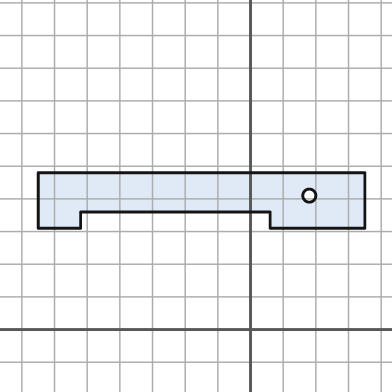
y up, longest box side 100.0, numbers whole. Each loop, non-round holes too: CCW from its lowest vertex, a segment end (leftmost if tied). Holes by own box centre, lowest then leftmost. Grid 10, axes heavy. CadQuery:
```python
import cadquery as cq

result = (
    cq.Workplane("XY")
    .moveTo(-65.0, 31.0)
    .lineTo(-52.0, 31.0)
    .lineTo(-52.0, 36.0)
    .lineTo(6.0, 36.0)
    .lineTo(6.0, 31.0)
    .lineTo(35.0, 31.0)
    .lineTo(35.0, 48.0)
    .lineTo(-65.0, 48.0)
    .close()
    .moveTo(18.0, 41.0)
    .circle(2.0)
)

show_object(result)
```